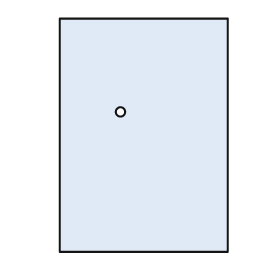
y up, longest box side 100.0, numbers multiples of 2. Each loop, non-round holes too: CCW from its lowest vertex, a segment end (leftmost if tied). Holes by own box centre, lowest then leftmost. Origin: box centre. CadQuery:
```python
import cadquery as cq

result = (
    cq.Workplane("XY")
    .moveTo(-36.0, -50.0)
    .lineTo(36.0, -50.0)
    .lineTo(36.0, 50.0)
    .lineTo(-36.0, 50.0)
    .close()
    .moveTo(-10.0, 10.0)
    .circle(2.0)
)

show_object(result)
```